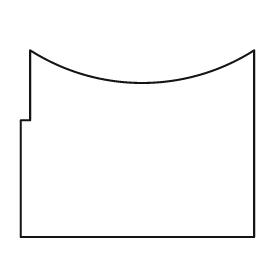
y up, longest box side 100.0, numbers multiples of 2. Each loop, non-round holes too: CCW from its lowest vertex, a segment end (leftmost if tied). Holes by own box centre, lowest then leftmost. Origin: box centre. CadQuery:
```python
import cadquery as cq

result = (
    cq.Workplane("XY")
    .moveTo(-50.0, -40.0)
    .lineTo(50.0, -40.0)
    .lineTo(50.0, 40.0)
    .threePointArc((2.0, 26.0), (-46.0, 40.0))
    .lineTo(-46.0, 10.0)
    .lineTo(-50.0, 10.0)
    .close()
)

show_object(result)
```